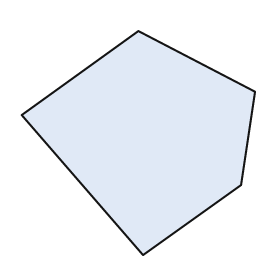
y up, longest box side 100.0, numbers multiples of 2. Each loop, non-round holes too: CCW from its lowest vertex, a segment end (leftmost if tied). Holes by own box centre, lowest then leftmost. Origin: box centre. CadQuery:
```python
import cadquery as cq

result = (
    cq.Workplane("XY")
    .moveTo(2.0, -48.0)
    .lineTo(44.0, -18.0)
    .lineTo(50.0, 22.0)
    .lineTo(0.0, 48.0)
    .lineTo(-50.0, 12.0)
    .close()
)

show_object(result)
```